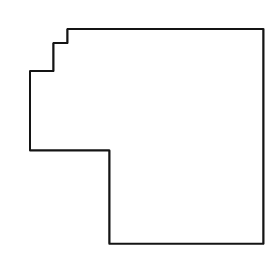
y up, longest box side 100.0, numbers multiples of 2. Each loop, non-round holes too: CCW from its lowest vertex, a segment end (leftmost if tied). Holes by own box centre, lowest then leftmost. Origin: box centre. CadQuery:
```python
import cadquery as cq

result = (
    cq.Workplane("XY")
    .moveTo(-16.0, -46.0)
    .lineTo(50.0, -46.0)
    .lineTo(50.0, 46.0)
    .lineTo(-34.0, 46.0)
    .lineTo(-34.0, 40.0)
    .lineTo(-40.0, 40.0)
    .lineTo(-40.0, 28.0)
    .lineTo(-50.0, 28.0)
    .lineTo(-50.0, -6.0)
    .lineTo(-16.0, -6.0)
    .close()
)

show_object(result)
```